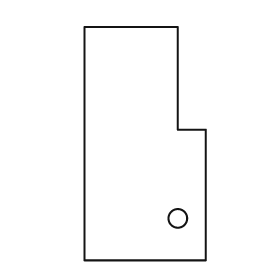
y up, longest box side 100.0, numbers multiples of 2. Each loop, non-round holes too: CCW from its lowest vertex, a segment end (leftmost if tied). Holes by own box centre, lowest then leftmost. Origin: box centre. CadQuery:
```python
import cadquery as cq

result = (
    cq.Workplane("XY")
    .moveTo(-26.0, -50.0)
    .lineTo(26.0, -50.0)
    .lineTo(26.0, 6.0)
    .lineTo(14.0, 6.0)
    .lineTo(14.0, 50.0)
    .lineTo(-26.0, 50.0)
    .close()
    .moveTo(14.0, -32.0)
    .circle(4.0)
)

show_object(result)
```